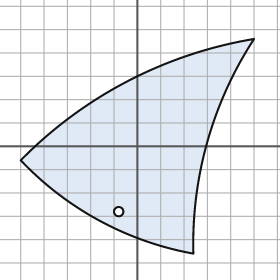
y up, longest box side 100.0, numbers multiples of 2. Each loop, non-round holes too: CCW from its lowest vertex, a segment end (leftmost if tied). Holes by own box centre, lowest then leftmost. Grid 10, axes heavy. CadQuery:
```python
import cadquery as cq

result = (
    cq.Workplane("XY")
    .moveTo(24.0, -46.0)
    .threePointArc((30.0, 2.0), (50.0, 46.0))
    .threePointArc((-4.0, 28.0), (-50.0, -6.0))
    .threePointArc((-16.0, -32.0), (24.0, -46.0))
    .close()
    .moveTo(-8.0, -28.0)
    .circle(2.0)
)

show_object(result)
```